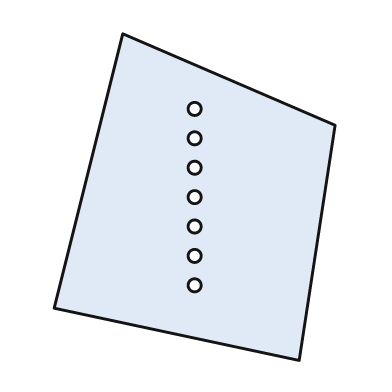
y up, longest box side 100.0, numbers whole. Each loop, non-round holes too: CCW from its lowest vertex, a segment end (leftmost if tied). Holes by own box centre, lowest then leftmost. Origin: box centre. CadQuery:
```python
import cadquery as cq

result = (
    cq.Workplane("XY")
    .moveTo(32.0, -50.0)
    .lineTo(43.0, 22.0)
    .lineTo(-22.0, 50.0)
    .lineTo(-43.0, -34.0)
    .close()
    .moveTo(0.0, -27.0)
    .circle(2.0)
    .moveTo(0.0, -18.0)
    .circle(2.0)
    .moveTo(0.0, -9.0)
    .circle(2.0)
    .moveTo(0.0, 0.0)
    .circle(2.0)
    .moveTo(0.0, 9.0)
    .circle(2.0)
    .moveTo(0.0, 18.0)
    .circle(2.0)
    .moveTo(0.0, 27.0)
    .circle(2.0)
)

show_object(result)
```